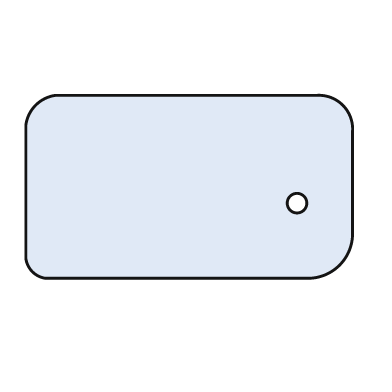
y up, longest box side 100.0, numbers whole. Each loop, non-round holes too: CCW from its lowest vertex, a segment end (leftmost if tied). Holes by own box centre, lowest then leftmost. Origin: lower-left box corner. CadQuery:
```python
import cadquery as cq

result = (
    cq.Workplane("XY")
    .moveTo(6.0, 0.0)
    .lineTo(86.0, 0.0)
    .threePointArc((96.0, 4.0), (100.0, 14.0))
    .lineTo(100.0, 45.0)
    .threePointArc((97.0, 53.0), (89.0, 56.0))
    .lineTo(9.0, 56.0)
    .threePointArc((3.0, 53.0), (0.0, 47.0))
    .lineTo(0.0, 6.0)
    .threePointArc((2.0, 2.0), (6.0, 0.0))
    .close()
    .moveTo(83.0, 23.0)
    .circle(3.0)
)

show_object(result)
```